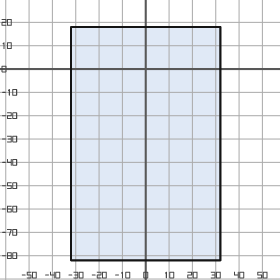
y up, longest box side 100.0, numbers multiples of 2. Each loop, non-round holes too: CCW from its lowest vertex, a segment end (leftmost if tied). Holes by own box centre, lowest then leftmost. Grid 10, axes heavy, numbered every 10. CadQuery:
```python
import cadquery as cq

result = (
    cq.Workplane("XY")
    .moveTo(-32.0, -82.0)
    .lineTo(32.0, -82.0)
    .lineTo(32.0, 18.0)
    .lineTo(-32.0, 18.0)
    .close()
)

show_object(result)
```